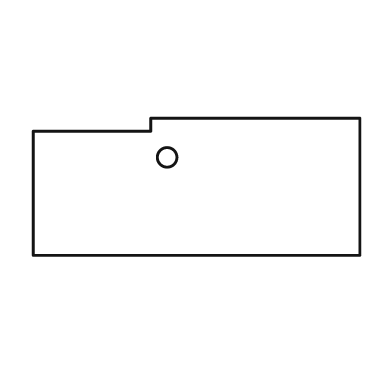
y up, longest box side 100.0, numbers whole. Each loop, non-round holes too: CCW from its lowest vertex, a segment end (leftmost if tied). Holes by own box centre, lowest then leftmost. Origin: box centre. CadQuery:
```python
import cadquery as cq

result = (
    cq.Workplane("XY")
    .moveTo(-50.0, -21.0)
    .lineTo(50.0, -21.0)
    .lineTo(50.0, 21.0)
    .lineTo(-14.0, 21.0)
    .lineTo(-14.0, 17.0)
    .lineTo(-50.0, 17.0)
    .close()
    .moveTo(-9.0, 9.0)
    .circle(3.0)
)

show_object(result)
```